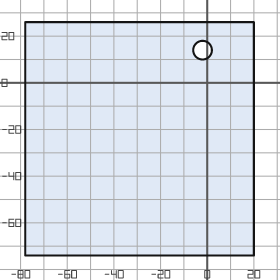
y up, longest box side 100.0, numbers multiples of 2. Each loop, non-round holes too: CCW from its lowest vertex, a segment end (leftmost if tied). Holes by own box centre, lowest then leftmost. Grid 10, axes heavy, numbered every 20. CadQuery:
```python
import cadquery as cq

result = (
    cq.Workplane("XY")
    .moveTo(-78.0, -74.0)
    .lineTo(20.0, -74.0)
    .lineTo(20.0, 26.0)
    .lineTo(-78.0, 26.0)
    .close()
    .moveTo(-2.0, 14.0)
    .circle(4.0)
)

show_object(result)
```